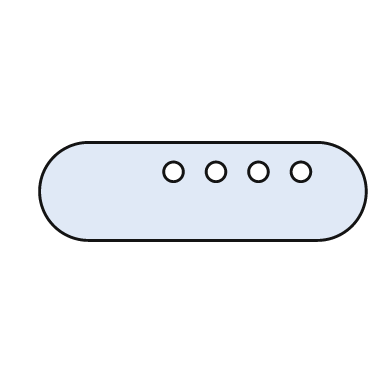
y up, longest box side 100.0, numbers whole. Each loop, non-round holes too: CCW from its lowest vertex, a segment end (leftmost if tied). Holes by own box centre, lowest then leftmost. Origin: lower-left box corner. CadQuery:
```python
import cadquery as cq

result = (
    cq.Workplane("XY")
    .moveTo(15.0, 0.0)
    .lineTo(85.0, 0.0)
    .threePointArc((100.0, 15.0), (85.0, 30.0))
    .lineTo(15.0, 30.0)
    .threePointArc((0.0, 15.0), (15.0, 0.0))
    .close()
    .moveTo(41.0, 21.0)
    .circle(3.0)
    .moveTo(54.0, 21.0)
    .circle(3.0)
    .moveTo(67.0, 21.0)
    .circle(3.0)
    .moveTo(80.0, 21.0)
    .circle(3.0)
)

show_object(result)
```